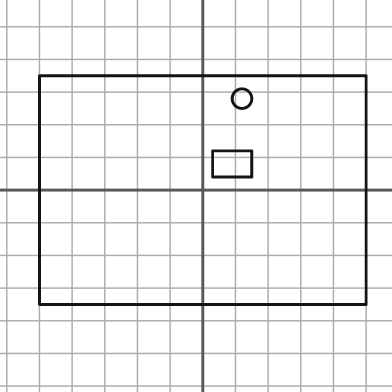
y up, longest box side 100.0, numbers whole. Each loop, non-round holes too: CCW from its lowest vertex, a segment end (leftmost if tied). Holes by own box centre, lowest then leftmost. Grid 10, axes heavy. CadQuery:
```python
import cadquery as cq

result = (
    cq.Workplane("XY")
    .moveTo(-50.0, -35.0)
    .lineTo(50.0, -35.0)
    .lineTo(50.0, 35.0)
    .lineTo(-50.0, 35.0)
    .close()
    .moveTo(3.0, 4.0)
    .lineTo(15.0, 4.0)
    .lineTo(15.0, 12.0)
    .lineTo(3.0, 12.0)
    .close()
    .moveTo(12.0, 28.0)
    .circle(3.0)
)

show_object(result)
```